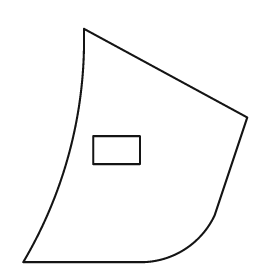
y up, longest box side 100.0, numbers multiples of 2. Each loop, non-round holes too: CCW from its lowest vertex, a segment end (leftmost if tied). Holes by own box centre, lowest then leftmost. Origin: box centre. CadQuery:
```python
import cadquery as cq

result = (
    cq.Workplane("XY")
    .moveTo(-48.0, -50.0)
    .lineTo(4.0, -50.0)
    .threePointArc((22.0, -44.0), (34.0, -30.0))
    .lineTo(48.0, 12.0)
    .lineTo(-22.0, 50.0)
    .threePointArc((-28.0, -2.0), (-48.0, -50.0))
    .close()
    .moveTo(-18.0, -8.0)
    .lineTo(2.0, -8.0)
    .lineTo(2.0, 4.0)
    .lineTo(-18.0, 4.0)
    .close()
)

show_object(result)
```